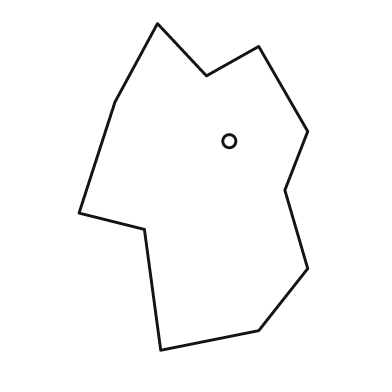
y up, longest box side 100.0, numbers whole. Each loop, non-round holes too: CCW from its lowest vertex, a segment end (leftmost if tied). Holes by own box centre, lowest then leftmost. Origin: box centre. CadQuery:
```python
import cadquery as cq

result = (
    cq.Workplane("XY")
    .moveTo(-10.0, -50.0)
    .lineTo(20.0, -44.0)
    .lineTo(35.0, -25.0)
    .lineTo(28.0, -1.0)
    .lineTo(35.0, 17.0)
    .lineTo(20.0, 43.0)
    .lineTo(4.0, 34.0)
    .lineTo(-11.0, 50.0)
    .lineTo(-24.0, 26.0)
    .lineTo(-35.0, -8.0)
    .lineTo(-15.0, -13.0)
    .close()
    .moveTo(11.0, 14.0)
    .circle(2.0)
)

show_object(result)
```